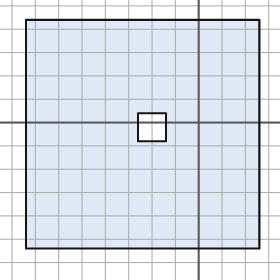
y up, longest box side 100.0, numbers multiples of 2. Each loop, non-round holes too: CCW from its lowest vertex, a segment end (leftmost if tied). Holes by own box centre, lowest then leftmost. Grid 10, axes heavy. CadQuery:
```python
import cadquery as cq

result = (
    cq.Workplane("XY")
    .moveTo(-74.0, -54.0)
    .lineTo(26.0, -54.0)
    .lineTo(26.0, 44.0)
    .lineTo(-74.0, 44.0)
    .close()
    .moveTo(-26.0, -8.0)
    .lineTo(-14.0, -8.0)
    .lineTo(-14.0, 4.0)
    .lineTo(-26.0, 4.0)
    .close()
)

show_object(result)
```